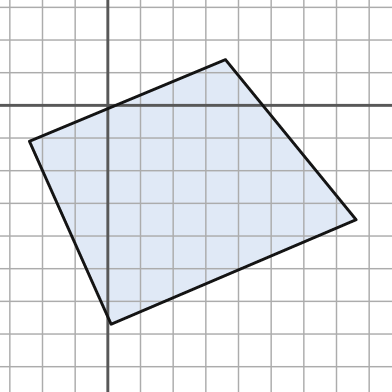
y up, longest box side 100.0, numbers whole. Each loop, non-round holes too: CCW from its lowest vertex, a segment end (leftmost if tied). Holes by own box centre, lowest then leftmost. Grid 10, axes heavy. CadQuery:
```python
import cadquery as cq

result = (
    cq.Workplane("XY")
    .moveTo(1.0, -67.0)
    .lineTo(76.0, -35.0)
    .lineTo(36.0, 14.0)
    .lineTo(-24.0, -11.0)
    .close()
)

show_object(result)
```